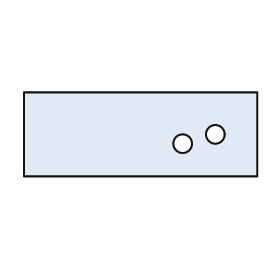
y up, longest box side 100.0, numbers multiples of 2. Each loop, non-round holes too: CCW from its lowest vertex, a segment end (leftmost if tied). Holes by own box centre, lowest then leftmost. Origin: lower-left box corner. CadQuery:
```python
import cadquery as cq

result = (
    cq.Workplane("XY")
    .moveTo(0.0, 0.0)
    .lineTo(100.0, 0.0)
    .lineTo(100.0, 36.0)
    .lineTo(0.0, 36.0)
    .close()
    .moveTo(68.0, 14.0)
    .circle(4.0)
    .moveTo(82.0, 18.0)
    .circle(4.0)
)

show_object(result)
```